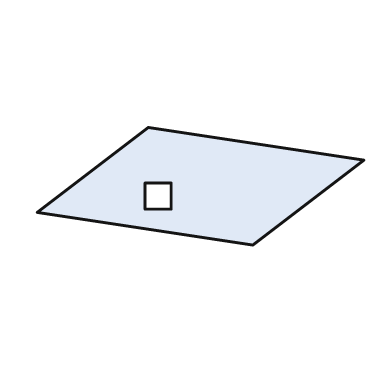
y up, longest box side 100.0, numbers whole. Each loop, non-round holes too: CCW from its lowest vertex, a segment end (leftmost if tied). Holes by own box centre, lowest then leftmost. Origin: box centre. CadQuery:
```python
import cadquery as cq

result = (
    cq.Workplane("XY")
    .moveTo(16.0, -18.0)
    .lineTo(50.0, 8.0)
    .lineTo(-16.0, 18.0)
    .lineTo(-50.0, -8.0)
    .close()
    .moveTo(-17.0, -7.0)
    .lineTo(-9.0, -7.0)
    .lineTo(-9.0, 1.0)
    .lineTo(-17.0, 1.0)
    .close()
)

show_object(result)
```